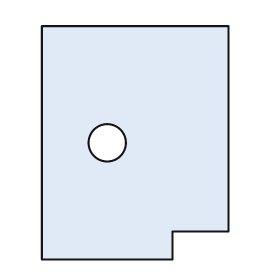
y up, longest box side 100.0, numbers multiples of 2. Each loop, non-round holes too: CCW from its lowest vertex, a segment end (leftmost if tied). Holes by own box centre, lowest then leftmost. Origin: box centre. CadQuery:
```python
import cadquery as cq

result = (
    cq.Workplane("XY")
    .moveTo(-40.0, -50.0)
    .lineTo(16.0, -50.0)
    .lineTo(16.0, -38.0)
    .lineTo(40.0, -38.0)
    .lineTo(40.0, 50.0)
    .lineTo(-40.0, 50.0)
    .close()
    .moveTo(-12.0, 0.0)
    .circle(8.0)
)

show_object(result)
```